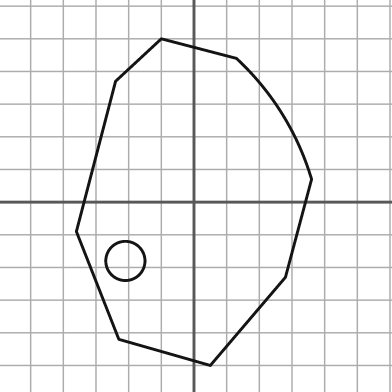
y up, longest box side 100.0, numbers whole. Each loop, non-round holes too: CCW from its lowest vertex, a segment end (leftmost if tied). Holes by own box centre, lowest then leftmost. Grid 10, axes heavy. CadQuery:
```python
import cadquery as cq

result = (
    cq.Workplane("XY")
    .moveTo(5.0, -50.0)
    .lineTo(28.0, -23.0)
    .lineTo(36.0, 7.0)
    .threePointArc((27.0, 27.0), (13.0, 44.0))
    .lineTo(-10.0, 50.0)
    .lineTo(-24.0, 37.0)
    .lineTo(-36.0, -9.0)
    .lineTo(-23.0, -42.0)
    .close()
    .moveTo(-21.0, -18.0)
    .circle(6.0)
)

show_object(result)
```